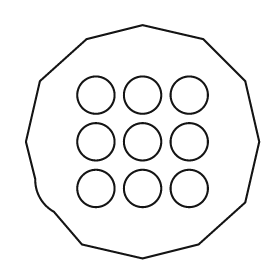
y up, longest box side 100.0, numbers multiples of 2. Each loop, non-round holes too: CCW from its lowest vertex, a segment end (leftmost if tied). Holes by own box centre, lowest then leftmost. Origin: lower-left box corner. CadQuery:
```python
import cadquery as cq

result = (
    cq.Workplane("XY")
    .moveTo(50.0, 0.0)
    .lineTo(74.0, 6.0)
    .lineTo(94.0, 24.0)
    .lineTo(100.0, 50.0)
    .lineTo(94.0, 76.0)
    .lineTo(76.0, 94.0)
    .lineTo(50.0, 100.0)
    .lineTo(26.0, 94.0)
    .lineTo(6.0, 76.0)
    .lineTo(0.0, 50.0)
    .lineTo(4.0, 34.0)
    .threePointArc((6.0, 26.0), (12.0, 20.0))
    .lineTo(24.0, 6.0)
    .close()
    .moveTo(30.0, 30.0)
    .circle(8.0)
    .moveTo(50.0, 30.0)
    .circle(8.0)
    .moveTo(70.0, 30.0)
    .circle(8.0)
    .moveTo(30.0, 50.0)
    .circle(8.0)
    .moveTo(50.0, 50.0)
    .circle(8.0)
    .moveTo(70.0, 50.0)
    .circle(8.0)
    .moveTo(30.0, 70.0)
    .circle(8.0)
    .moveTo(50.0, 70.0)
    .circle(8.0)
    .moveTo(70.0, 70.0)
    .circle(8.0)
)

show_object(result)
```